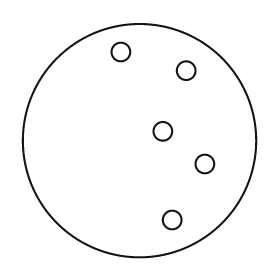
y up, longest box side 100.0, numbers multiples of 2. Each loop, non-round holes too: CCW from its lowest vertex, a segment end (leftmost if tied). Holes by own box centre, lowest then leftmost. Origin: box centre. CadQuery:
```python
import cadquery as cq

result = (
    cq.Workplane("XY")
    .moveTo(0.0, 0.0)
    .circle(50.0)
    .moveTo(14.0, -34.0)
    .circle(4.0)
    .moveTo(28.0, -10.0)
    .circle(4.0)
    .moveTo(10.0, 4.0)
    .circle(4.0)
    .moveTo(20.0, 30.0)
    .circle(4.0)
    .moveTo(-8.0, 38.0)
    .circle(4.0)
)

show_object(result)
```